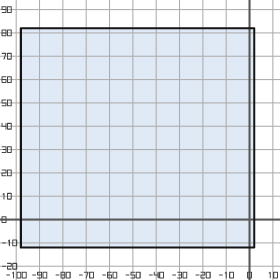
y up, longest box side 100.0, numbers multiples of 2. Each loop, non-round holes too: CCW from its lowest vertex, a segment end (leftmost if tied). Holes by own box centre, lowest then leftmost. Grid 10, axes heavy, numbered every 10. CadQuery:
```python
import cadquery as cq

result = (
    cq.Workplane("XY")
    .moveTo(-98.0, -12.0)
    .lineTo(2.0, -12.0)
    .lineTo(2.0, 82.0)
    .lineTo(-98.0, 82.0)
    .close()
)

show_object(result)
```